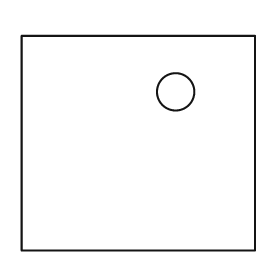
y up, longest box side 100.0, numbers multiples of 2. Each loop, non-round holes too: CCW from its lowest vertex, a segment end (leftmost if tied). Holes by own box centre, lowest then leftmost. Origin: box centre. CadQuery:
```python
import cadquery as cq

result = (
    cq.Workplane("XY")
    .moveTo(-50.0, -46.0)
    .lineTo(50.0, -46.0)
    .lineTo(50.0, 46.0)
    .lineTo(-50.0, 46.0)
    .close()
    .moveTo(16.0, 22.0)
    .circle(8.0)
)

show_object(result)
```